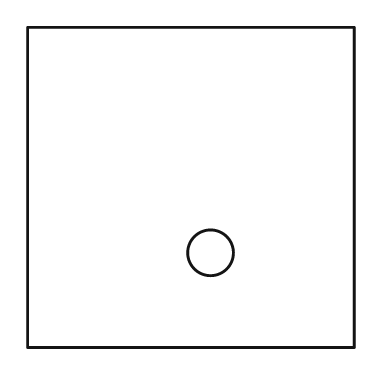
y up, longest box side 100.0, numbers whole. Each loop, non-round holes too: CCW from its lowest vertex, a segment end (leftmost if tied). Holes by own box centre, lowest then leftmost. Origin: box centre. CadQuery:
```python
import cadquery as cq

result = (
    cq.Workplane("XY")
    .moveTo(-50.0, -49.0)
    .lineTo(50.0, -49.0)
    .lineTo(50.0, 49.0)
    .lineTo(-50.0, 49.0)
    .close()
    .moveTo(6.0, -20.0)
    .circle(7.0)
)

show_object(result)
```